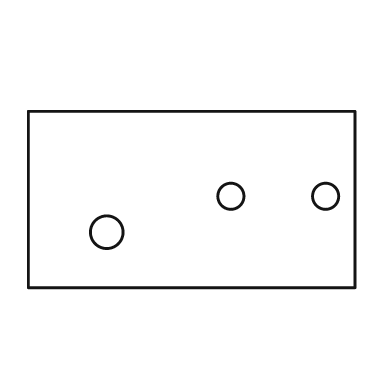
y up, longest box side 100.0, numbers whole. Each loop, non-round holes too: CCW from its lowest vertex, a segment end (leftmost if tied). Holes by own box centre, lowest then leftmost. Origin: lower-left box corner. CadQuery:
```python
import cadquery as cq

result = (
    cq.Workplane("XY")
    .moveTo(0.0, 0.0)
    .lineTo(100.0, 0.0)
    .lineTo(100.0, 54.0)
    .lineTo(0.0, 54.0)
    .close()
    .moveTo(24.0, 17.0)
    .circle(5.0)
    .moveTo(62.0, 28.0)
    .circle(4.0)
    .moveTo(91.0, 28.0)
    .circle(4.0)
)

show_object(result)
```